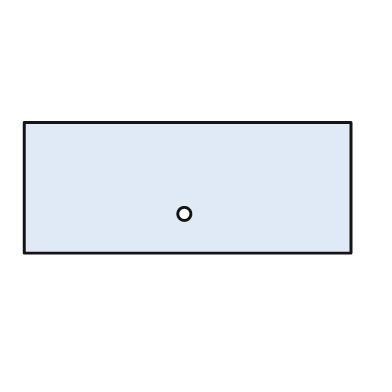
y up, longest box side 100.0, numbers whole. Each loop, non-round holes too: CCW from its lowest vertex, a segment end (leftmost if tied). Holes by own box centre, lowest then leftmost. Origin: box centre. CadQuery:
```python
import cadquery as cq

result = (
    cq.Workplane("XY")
    .moveTo(-50.0, -20.0)
    .lineTo(50.0, -20.0)
    .lineTo(50.0, 20.0)
    .lineTo(-50.0, 20.0)
    .close()
    .moveTo(-1.0, -8.0)
    .circle(2.0)
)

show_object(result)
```